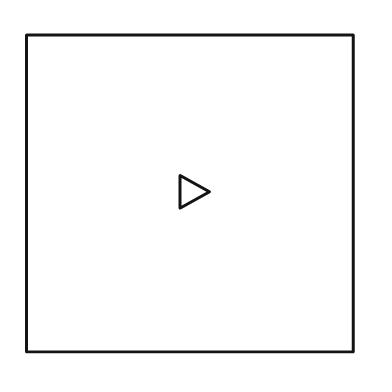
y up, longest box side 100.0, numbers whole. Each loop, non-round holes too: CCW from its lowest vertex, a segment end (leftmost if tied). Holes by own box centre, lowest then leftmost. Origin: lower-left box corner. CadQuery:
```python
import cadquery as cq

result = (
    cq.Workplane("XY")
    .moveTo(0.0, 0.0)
    .lineTo(100.0, 0.0)
    .lineTo(100.0, 97.0)
    .lineTo(0.0, 97.0)
    .close()
    .moveTo(47.0, 44.0)
    .lineTo(56.0, 49.0)
    .lineTo(47.0, 54.0)
    .close()
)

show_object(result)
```